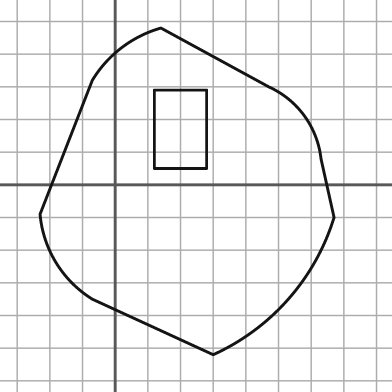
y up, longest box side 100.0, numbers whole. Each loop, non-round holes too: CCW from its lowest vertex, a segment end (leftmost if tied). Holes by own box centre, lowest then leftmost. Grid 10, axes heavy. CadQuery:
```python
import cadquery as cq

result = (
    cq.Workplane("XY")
    .moveTo(30.0, -52.0)
    .threePointArc((53.0, -35.0), (67.0, -10.0))
    .lineTo(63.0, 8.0)
    .threePointArc((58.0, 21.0), (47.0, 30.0))
    .lineTo(14.0, 48.0)
    .threePointArc((2.0, 42.0), (-7.0, 32.0))
    .lineTo(-23.0, -9.0)
    .threePointArc((-18.0, -24.0), (-7.0, -35.0))
    .close()
    .moveTo(12.0, 5.0)
    .lineTo(28.0, 5.0)
    .lineTo(28.0, 29.0)
    .lineTo(12.0, 29.0)
    .close()
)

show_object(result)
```